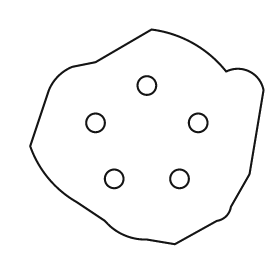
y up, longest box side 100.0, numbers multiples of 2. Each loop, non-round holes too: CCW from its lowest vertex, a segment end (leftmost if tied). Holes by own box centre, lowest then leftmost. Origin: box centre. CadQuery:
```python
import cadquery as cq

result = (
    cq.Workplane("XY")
    .moveTo(12.0, -46.0)
    .lineTo(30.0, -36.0)
    .threePointArc((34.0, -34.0), (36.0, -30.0))
    .lineTo(44.0, -16.0)
    .lineTo(50.0, 20.0)
    .threePointArc((44.0, 28.0), (34.0, 28.0))
    .threePointArc((20.0, 40.0), (2.0, 46.0))
    .lineTo(-22.0, 32.0)
    .lineTo(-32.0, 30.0)
    .threePointArc((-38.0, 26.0), (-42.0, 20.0))
    .lineTo(-50.0, -4.0)
    .threePointArc((-42.0, -18.0), (-30.0, -28.0))
    .lineTo(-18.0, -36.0)
    .threePointArc((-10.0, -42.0), (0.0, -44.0))
    .close()
    .moveTo(-14.0, -18.0)
    .circle(4.0)
    .moveTo(14.0, -18.0)
    .circle(4.0)
    .moveTo(-22.0, 6.0)
    .circle(4.0)
    .moveTo(22.0, 6.0)
    .circle(4.0)
    .moveTo(0.0, 22.0)
    .circle(4.0)
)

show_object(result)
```